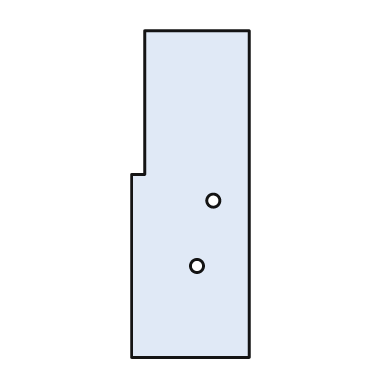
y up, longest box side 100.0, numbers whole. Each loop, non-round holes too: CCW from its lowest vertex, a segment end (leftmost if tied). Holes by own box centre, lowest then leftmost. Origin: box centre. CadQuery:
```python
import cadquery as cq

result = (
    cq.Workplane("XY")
    .moveTo(-18.0, -50.0)
    .lineTo(18.0, -50.0)
    .lineTo(18.0, 50.0)
    .lineTo(-14.0, 50.0)
    .lineTo(-14.0, 6.0)
    .lineTo(-18.0, 6.0)
    .close()
    .moveTo(2.0, -22.0)
    .circle(2.0)
    .moveTo(7.0, -2.0)
    .circle(2.0)
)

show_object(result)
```